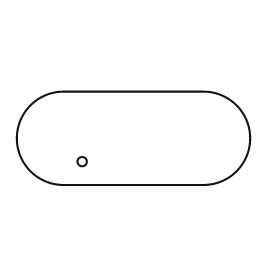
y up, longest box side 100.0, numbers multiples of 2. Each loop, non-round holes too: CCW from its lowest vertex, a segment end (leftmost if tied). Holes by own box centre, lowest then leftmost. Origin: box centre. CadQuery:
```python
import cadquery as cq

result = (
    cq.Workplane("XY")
    .moveTo(-30.0, -20.0)
    .lineTo(30.0, -20.0)
    .threePointArc((50.0, 0.0), (30.0, 20.0))
    .lineTo(-30.0, 20.0)
    .threePointArc((-50.0, 0.0), (-30.0, -20.0))
    .close()
    .moveTo(-22.0, -10.0)
    .circle(2.0)
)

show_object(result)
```